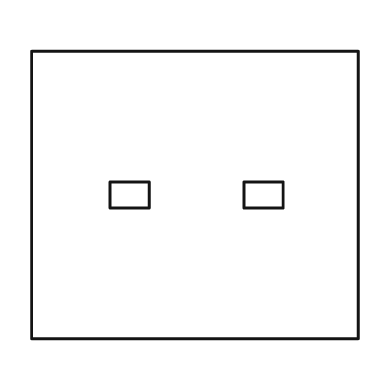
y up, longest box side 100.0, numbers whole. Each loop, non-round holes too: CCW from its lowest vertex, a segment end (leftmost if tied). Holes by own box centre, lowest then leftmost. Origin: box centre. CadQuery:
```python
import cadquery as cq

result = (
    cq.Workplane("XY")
    .moveTo(-50.0, -44.0)
    .lineTo(50.0, -44.0)
    .lineTo(50.0, 44.0)
    .lineTo(-50.0, 44.0)
    .close()
    .moveTo(-26.0, -4.0)
    .lineTo(-14.0, -4.0)
    .lineTo(-14.0, 4.0)
    .lineTo(-26.0, 4.0)
    .close()
    .moveTo(15.0, -4.0)
    .lineTo(27.0, -4.0)
    .lineTo(27.0, 4.0)
    .lineTo(15.0, 4.0)
    .close()
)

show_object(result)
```